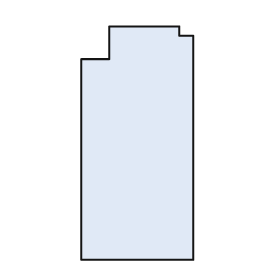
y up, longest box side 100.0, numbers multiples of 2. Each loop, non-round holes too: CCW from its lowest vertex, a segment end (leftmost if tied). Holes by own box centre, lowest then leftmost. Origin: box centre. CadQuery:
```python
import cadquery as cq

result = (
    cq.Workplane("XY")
    .moveTo(-24.0, -50.0)
    .lineTo(24.0, -50.0)
    .lineTo(24.0, 46.0)
    .lineTo(18.0, 46.0)
    .lineTo(18.0, 50.0)
    .lineTo(-12.0, 50.0)
    .lineTo(-12.0, 36.0)
    .lineTo(-24.0, 36.0)
    .close()
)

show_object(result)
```